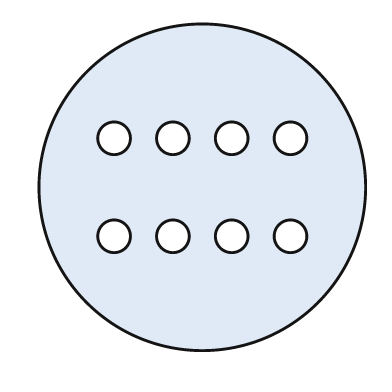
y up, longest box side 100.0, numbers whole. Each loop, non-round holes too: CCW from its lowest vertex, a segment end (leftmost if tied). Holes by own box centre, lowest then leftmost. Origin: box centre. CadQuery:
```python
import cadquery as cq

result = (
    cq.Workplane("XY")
    .moveTo(0.0, 0.0)
    .circle(50.0)
    .moveTo(-27.0, -15.0)
    .circle(5.0)
    .moveTo(-9.0, -15.0)
    .circle(5.0)
    .moveTo(9.0, -15.0)
    .circle(5.0)
    .moveTo(27.0, -15.0)
    .circle(5.0)
    .moveTo(-27.0, 15.0)
    .circle(5.0)
    .moveTo(-9.0, 15.0)
    .circle(5.0)
    .moveTo(9.0, 15.0)
    .circle(5.0)
    .moveTo(27.0, 15.0)
    .circle(5.0)
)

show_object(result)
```